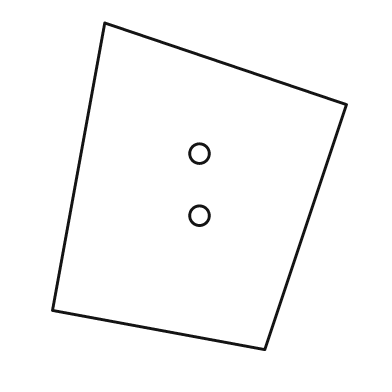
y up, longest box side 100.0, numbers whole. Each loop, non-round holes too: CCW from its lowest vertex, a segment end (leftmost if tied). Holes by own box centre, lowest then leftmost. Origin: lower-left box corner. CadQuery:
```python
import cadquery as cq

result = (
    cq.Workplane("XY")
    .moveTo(65.0, 0.0)
    .lineTo(90.0, 75.0)
    .lineTo(16.0, 100.0)
    .lineTo(0.0, 12.0)
    .close()
    .moveTo(45.0, 41.0)
    .circle(3.0)
    .moveTo(45.0, 60.0)
    .circle(3.0)
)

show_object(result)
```